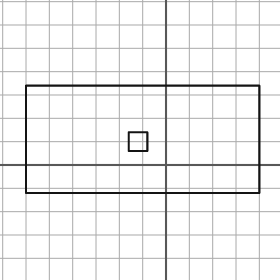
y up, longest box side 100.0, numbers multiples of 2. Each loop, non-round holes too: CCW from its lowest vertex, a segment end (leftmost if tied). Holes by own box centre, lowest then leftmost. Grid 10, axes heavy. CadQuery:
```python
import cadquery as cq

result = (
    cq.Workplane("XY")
    .moveTo(-60.0, -12.0)
    .lineTo(40.0, -12.0)
    .lineTo(40.0, 34.0)
    .lineTo(-60.0, 34.0)
    .close()
    .moveTo(-16.0, 6.0)
    .lineTo(-8.0, 6.0)
    .lineTo(-8.0, 14.0)
    .lineTo(-16.0, 14.0)
    .close()
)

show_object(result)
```